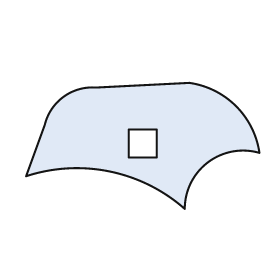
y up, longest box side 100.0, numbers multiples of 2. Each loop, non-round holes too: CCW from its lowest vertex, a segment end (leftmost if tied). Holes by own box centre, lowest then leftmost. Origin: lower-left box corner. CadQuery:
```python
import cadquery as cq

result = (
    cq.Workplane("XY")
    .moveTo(68.0, 0.0)
    .threePointArc((78.0, 20.0), (100.0, 24.0))
    .threePointArc((90.0, 44.0), (70.0, 54.0))
    .lineTo(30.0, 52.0)
    .threePointArc((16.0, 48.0), (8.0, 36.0))
    .lineTo(0.0, 14.0)
    .threePointArc((36.0, 16.0), (68.0, 0.0))
    .close()
    .moveTo(44.0, 22.0)
    .lineTo(56.0, 22.0)
    .lineTo(56.0, 34.0)
    .lineTo(44.0, 34.0)
    .close()
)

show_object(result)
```